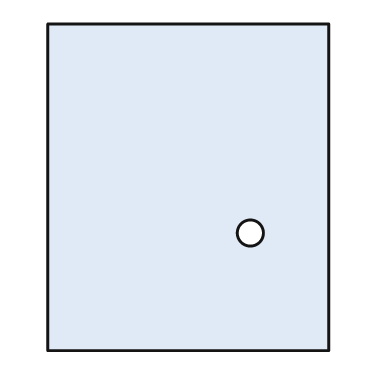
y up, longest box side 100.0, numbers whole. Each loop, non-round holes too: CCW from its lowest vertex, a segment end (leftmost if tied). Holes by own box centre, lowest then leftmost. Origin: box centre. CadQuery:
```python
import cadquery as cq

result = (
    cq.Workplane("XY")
    .moveTo(-43.0, -50.0)
    .lineTo(43.0, -50.0)
    .lineTo(43.0, 50.0)
    .lineTo(-43.0, 50.0)
    .close()
    .moveTo(19.0, -14.0)
    .circle(4.0)
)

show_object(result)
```